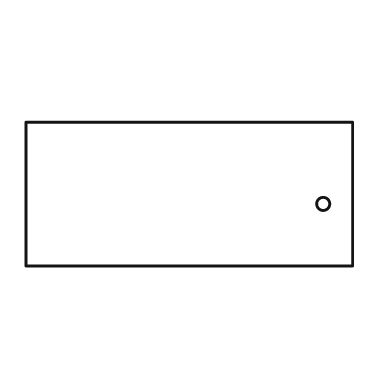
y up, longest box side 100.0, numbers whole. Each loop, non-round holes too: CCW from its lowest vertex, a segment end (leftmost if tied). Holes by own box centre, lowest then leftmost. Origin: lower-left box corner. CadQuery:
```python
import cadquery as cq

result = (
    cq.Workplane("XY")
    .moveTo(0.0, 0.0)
    .lineTo(100.0, 0.0)
    .lineTo(100.0, 44.0)
    .lineTo(0.0, 44.0)
    .close()
    .moveTo(91.0, 19.0)
    .circle(2.0)
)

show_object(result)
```